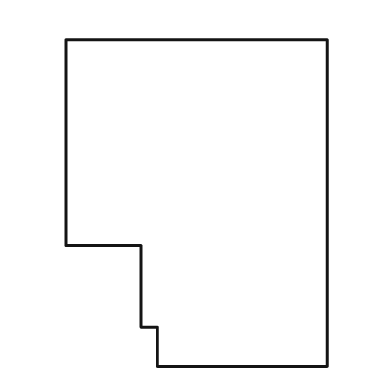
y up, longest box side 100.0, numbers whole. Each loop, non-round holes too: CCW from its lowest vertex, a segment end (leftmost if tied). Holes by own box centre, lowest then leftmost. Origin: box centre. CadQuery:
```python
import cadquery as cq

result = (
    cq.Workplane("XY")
    .moveTo(-12.0, -50.0)
    .lineTo(40.0, -50.0)
    .lineTo(40.0, 50.0)
    .lineTo(-40.0, 50.0)
    .lineTo(-40.0, -13.0)
    .lineTo(-17.0, -13.0)
    .lineTo(-17.0, -38.0)
    .lineTo(-12.0, -38.0)
    .close()
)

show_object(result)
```